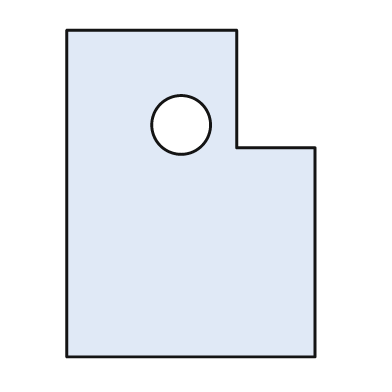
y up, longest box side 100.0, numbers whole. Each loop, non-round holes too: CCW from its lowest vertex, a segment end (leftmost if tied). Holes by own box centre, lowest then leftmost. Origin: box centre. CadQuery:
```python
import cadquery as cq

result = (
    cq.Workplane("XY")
    .moveTo(-38.0, -50.0)
    .lineTo(38.0, -50.0)
    .lineTo(38.0, 14.0)
    .lineTo(14.0, 14.0)
    .lineTo(14.0, 50.0)
    .lineTo(-38.0, 50.0)
    .close()
    .moveTo(-3.0, 21.0)
    .circle(9.0)
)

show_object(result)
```